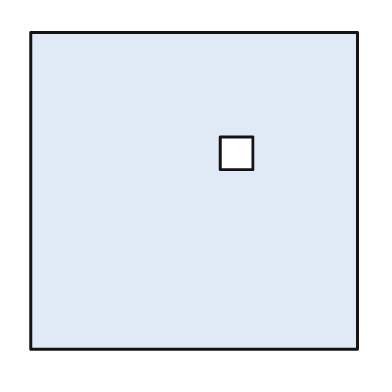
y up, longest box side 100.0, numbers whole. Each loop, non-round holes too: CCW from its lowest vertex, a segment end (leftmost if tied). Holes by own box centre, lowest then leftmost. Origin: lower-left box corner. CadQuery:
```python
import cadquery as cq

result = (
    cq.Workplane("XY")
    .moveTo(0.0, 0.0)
    .lineTo(100.0, 0.0)
    .lineTo(100.0, 97.0)
    .lineTo(0.0, 97.0)
    .close()
    .moveTo(58.0, 55.0)
    .lineTo(68.0, 55.0)
    .lineTo(68.0, 65.0)
    .lineTo(58.0, 65.0)
    .close()
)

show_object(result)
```